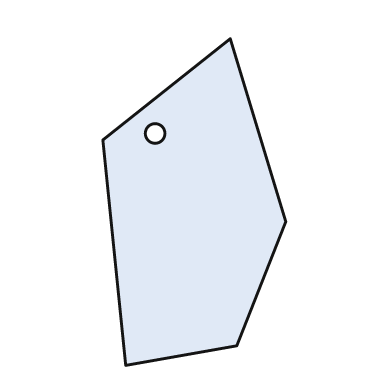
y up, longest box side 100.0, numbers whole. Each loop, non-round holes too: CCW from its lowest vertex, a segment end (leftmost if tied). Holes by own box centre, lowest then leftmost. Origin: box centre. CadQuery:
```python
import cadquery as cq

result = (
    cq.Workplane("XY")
    .moveTo(-21.0, -50.0)
    .lineTo(13.0, -44.0)
    .lineTo(28.0, -6.0)
    .lineTo(11.0, 50.0)
    .lineTo(-28.0, 19.0)
    .close()
    .moveTo(-12.0, 21.0)
    .circle(3.0)
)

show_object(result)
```